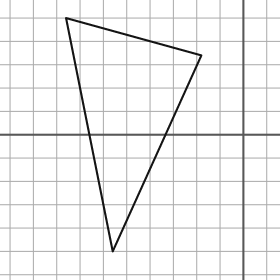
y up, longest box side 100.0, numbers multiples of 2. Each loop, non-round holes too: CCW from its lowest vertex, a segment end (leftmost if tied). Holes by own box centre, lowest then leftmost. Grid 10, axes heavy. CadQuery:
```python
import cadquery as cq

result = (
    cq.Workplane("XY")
    .moveTo(-56.0, -50.0)
    .lineTo(-18.0, 34.0)
    .lineTo(-76.0, 50.0)
    .close()
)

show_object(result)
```